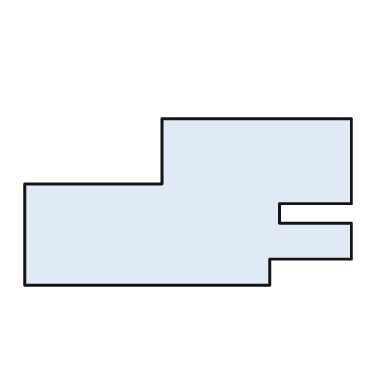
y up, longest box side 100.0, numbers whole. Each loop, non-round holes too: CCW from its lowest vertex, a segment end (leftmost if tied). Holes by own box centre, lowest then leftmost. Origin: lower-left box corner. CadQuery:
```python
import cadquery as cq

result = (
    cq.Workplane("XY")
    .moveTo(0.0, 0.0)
    .lineTo(75.0, 0.0)
    .lineTo(75.0, 8.0)
    .lineTo(100.0, 8.0)
    .lineTo(100.0, 19.0)
    .lineTo(78.0, 19.0)
    .lineTo(78.0, 25.0)
    .lineTo(100.0, 25.0)
    .lineTo(100.0, 51.0)
    .lineTo(42.0, 51.0)
    .lineTo(42.0, 31.0)
    .lineTo(0.0, 31.0)
    .close()
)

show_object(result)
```